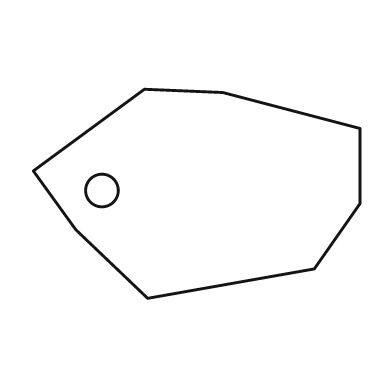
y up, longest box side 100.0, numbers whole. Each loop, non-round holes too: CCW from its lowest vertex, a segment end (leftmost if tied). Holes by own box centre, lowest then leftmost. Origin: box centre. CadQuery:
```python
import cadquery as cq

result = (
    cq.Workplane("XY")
    .moveTo(-15.0, -32.0)
    .lineTo(36.0, -23.0)
    .lineTo(50.0, -3.0)
    .lineTo(50.0, 20.0)
    .lineTo(8.0, 31.0)
    .lineTo(-16.0, 32.0)
    .lineTo(-50.0, 7.0)
    .lineTo(-37.0, -11.0)
    .close()
    .moveTo(-29.0, 1.0)
    .circle(5.0)
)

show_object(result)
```